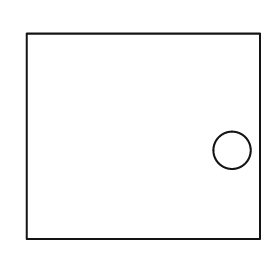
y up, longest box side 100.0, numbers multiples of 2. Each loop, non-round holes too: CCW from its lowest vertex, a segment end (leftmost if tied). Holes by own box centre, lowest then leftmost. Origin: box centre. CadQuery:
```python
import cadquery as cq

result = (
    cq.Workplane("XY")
    .moveTo(-50.0, -44.0)
    .lineTo(50.0, -44.0)
    .lineTo(50.0, 44.0)
    .lineTo(-50.0, 44.0)
    .close()
    .moveTo(38.0, -6.0)
    .circle(8.0)
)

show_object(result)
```